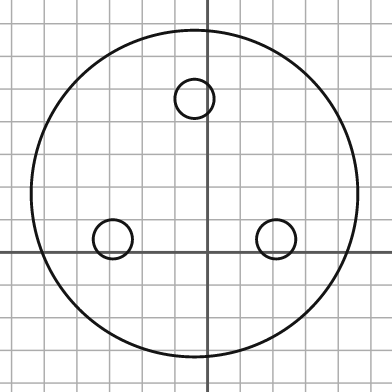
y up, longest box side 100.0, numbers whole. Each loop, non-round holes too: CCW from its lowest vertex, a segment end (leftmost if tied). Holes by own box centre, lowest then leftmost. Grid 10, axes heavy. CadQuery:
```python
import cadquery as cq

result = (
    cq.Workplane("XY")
    .moveTo(-4.0, 18.0)
    .circle(50.0)
    .moveTo(-29.0, 4.0)
    .circle(6.0)
    .moveTo(21.0, 4.0)
    .circle(6.0)
    .moveTo(-4.0, 47.0)
    .circle(6.0)
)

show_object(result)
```